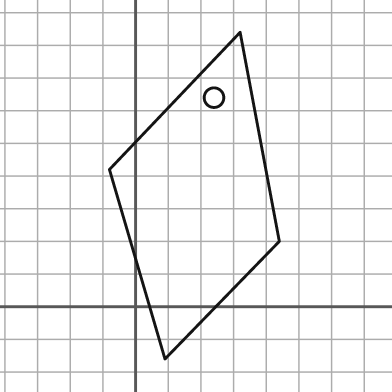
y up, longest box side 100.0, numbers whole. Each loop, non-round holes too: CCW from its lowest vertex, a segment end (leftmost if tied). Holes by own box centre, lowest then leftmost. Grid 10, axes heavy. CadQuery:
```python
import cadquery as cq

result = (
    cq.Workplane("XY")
    .moveTo(9.0, -16.0)
    .lineTo(44.0, 20.0)
    .lineTo(32.0, 84.0)
    .lineTo(-8.0, 42.0)
    .close()
    .moveTo(24.0, 64.0)
    .circle(3.0)
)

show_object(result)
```